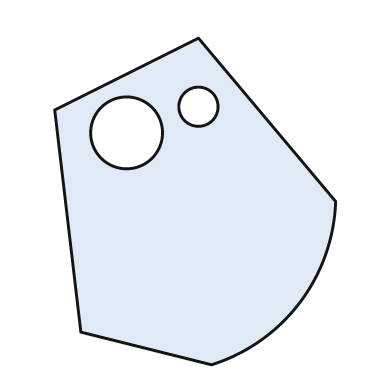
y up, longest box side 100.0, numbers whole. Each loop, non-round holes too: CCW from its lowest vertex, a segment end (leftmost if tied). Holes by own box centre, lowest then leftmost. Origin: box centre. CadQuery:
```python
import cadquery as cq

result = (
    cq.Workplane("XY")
    .moveTo(5.0, -50.0)
    .threePointArc((32.0, -31.0), (43.0, 0.0))
    .lineTo(1.0, 50.0)
    .lineTo(-43.0, 28.0)
    .lineTo(-35.0, -40.0)
    .close()
    .moveTo(-21.0, 21.0)
    .circle(11.0)
    .moveTo(1.0, 29.0)
    .circle(6.0)
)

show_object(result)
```